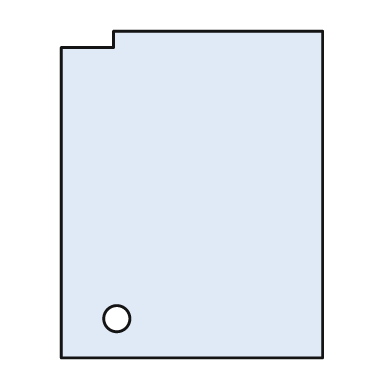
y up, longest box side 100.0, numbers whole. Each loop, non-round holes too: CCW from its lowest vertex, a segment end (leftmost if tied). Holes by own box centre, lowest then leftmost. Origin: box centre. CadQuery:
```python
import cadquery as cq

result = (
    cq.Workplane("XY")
    .moveTo(-40.0, -50.0)
    .lineTo(40.0, -50.0)
    .lineTo(40.0, 50.0)
    .lineTo(-24.0, 50.0)
    .lineTo(-24.0, 45.0)
    .lineTo(-40.0, 45.0)
    .close()
    .moveTo(-23.0, -38.0)
    .circle(4.0)
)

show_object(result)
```